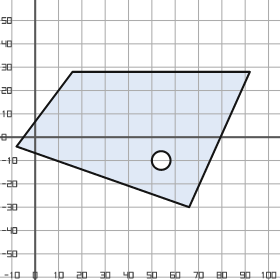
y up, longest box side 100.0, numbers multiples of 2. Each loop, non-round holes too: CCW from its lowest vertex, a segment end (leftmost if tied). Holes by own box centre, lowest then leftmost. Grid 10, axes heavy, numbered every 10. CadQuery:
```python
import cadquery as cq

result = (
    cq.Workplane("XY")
    .moveTo(66.0, -30.0)
    .lineTo(92.0, 28.0)
    .lineTo(16.0, 28.0)
    .lineTo(-8.0, -4.0)
    .close()
    .moveTo(54.0, -10.0)
    .circle(4.0)
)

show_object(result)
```